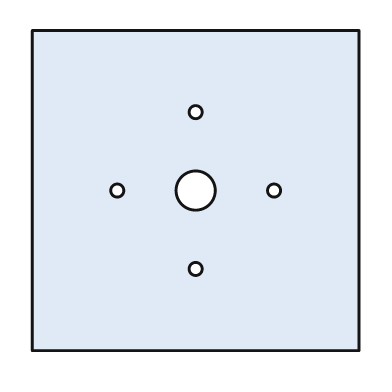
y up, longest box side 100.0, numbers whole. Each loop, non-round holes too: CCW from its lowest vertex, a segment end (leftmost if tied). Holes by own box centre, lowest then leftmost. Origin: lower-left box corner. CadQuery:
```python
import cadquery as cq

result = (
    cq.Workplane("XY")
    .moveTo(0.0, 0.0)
    .lineTo(100.0, 0.0)
    .lineTo(100.0, 98.0)
    .lineTo(0.0, 98.0)
    .close()
    .moveTo(50.0, 25.0)
    .circle(2.0)
    .moveTo(26.0, 49.0)
    .circle(2.0)
    .moveTo(50.0, 49.0)
    .circle(6.0)
    .moveTo(74.0, 49.0)
    .circle(2.0)
    .moveTo(50.0, 73.0)
    .circle(2.0)
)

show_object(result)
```